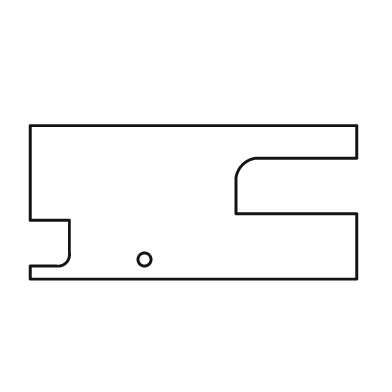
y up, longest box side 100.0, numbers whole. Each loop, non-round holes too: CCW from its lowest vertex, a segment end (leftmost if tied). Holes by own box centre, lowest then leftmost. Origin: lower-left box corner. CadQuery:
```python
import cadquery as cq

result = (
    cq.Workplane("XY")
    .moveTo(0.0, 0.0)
    .lineTo(100.0, 0.0)
    .lineTo(100.0, 20.0)
    .lineTo(63.0, 20.0)
    .lineTo(63.0, 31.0)
    .threePointArc((65.0, 35.0), (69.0, 37.0))
    .lineTo(100.0, 37.0)
    .lineTo(100.0, 47.0)
    .lineTo(0.0, 47.0)
    .lineTo(0.0, 18.0)
    .lineTo(12.0, 18.0)
    .lineTo(12.0, 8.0)
    .threePointArc((11.0, 5.0), (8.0, 4.0))
    .lineTo(0.0, 4.0)
    .close()
    .moveTo(35.0, 6.0)
    .circle(2.0)
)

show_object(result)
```